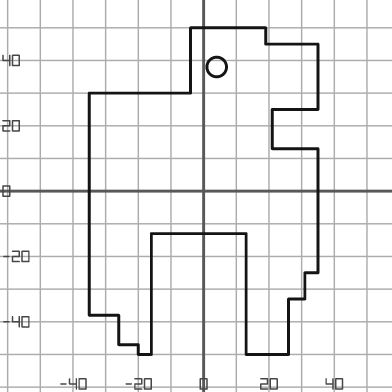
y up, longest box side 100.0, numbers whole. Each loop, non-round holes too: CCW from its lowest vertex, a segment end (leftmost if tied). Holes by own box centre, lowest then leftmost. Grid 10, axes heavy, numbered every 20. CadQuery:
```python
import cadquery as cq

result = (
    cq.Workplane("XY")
    .moveTo(-20.0, -50.0)
    .lineTo(-16.0, -50.0)
    .lineTo(-16.0, -13.0)
    .lineTo(13.0, -13.0)
    .lineTo(13.0, -50.0)
    .lineTo(26.0, -50.0)
    .lineTo(26.0, -33.0)
    .lineTo(31.0, -33.0)
    .lineTo(31.0, -25.0)
    .lineTo(35.0, -25.0)
    .lineTo(35.0, 13.0)
    .lineTo(21.0, 13.0)
    .lineTo(21.0, 25.0)
    .lineTo(35.0, 25.0)
    .lineTo(35.0, 45.0)
    .lineTo(19.0, 45.0)
    .lineTo(19.0, 50.0)
    .lineTo(-4.0, 50.0)
    .lineTo(-4.0, 30.0)
    .lineTo(-35.0, 30.0)
    .lineTo(-35.0, -38.0)
    .lineTo(-26.0, -38.0)
    .lineTo(-26.0, -47.0)
    .lineTo(-20.0, -47.0)
    .close()
    .moveTo(4.0, 38.0)
    .circle(3.0)
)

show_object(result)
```